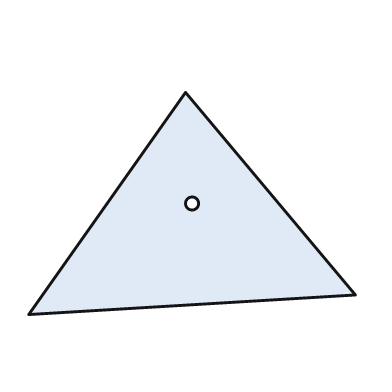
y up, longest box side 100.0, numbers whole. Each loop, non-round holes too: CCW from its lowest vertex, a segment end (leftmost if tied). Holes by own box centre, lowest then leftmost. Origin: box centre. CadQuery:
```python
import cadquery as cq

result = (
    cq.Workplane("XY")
    .moveTo(-50.0, -34.0)
    .lineTo(50.0, -28.0)
    .lineTo(-2.0, 34.0)
    .close()
    .moveTo(0.0, 0.0)
    .circle(2.0)
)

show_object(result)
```